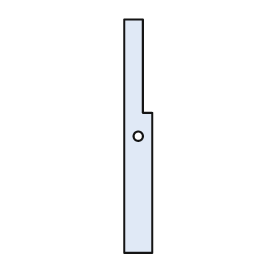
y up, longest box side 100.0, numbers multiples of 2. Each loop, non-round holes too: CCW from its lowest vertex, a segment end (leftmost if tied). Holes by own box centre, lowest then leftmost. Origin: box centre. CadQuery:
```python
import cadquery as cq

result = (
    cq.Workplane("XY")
    .moveTo(-6.0, -50.0)
    .lineTo(6.0, -50.0)
    .lineTo(6.0, 10.0)
    .lineTo(2.0, 10.0)
    .lineTo(2.0, 50.0)
    .lineTo(-6.0, 50.0)
    .close()
    .moveTo(0.0, 0.0)
    .circle(2.0)
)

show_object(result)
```